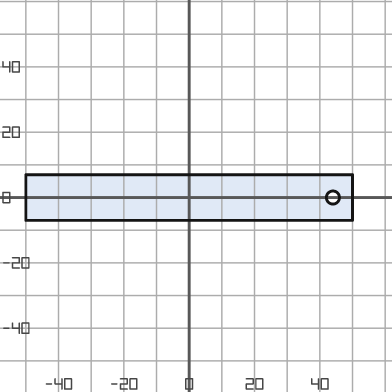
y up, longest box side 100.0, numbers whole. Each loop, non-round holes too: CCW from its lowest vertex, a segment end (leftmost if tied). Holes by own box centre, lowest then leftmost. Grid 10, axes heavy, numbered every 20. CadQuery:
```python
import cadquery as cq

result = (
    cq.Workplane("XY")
    .moveTo(-50.0, -7.0)
    .lineTo(50.0, -7.0)
    .lineTo(50.0, 7.0)
    .lineTo(-50.0, 7.0)
    .close()
    .moveTo(44.0, 0.0)
    .circle(2.0)
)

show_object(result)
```